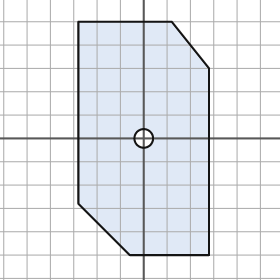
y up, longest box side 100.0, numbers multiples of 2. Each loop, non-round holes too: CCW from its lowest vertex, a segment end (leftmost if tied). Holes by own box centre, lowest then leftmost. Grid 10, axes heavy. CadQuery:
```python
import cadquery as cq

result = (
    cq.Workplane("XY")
    .moveTo(-6.0, -50.0)
    .lineTo(28.0, -50.0)
    .lineTo(28.0, 30.0)
    .lineTo(12.0, 50.0)
    .lineTo(-28.0, 50.0)
    .lineTo(-28.0, -28.0)
    .close()
    .moveTo(0.0, 0.0)
    .circle(4.0)
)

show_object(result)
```